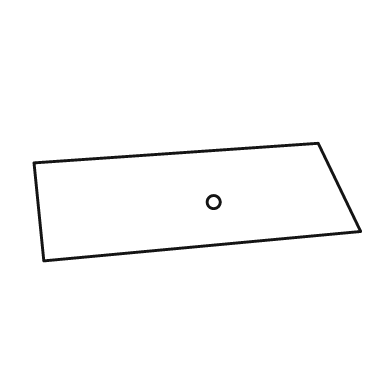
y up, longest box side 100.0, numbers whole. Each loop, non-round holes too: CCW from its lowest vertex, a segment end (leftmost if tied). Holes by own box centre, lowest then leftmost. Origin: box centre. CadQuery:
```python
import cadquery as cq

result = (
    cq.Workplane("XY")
    .moveTo(-47.0, -18.0)
    .lineTo(50.0, -9.0)
    .lineTo(37.0, 18.0)
    .lineTo(-50.0, 12.0)
    .close()
    .moveTo(5.0, 0.0)
    .circle(2.0)
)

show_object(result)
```